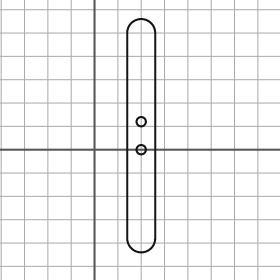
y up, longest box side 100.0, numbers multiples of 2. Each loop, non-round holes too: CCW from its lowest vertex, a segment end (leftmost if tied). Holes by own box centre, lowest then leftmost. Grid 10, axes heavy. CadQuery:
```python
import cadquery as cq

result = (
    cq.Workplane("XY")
    .moveTo(14.0, -38.0)
    .threePointArc((20.0, -44.0), (26.0, -38.0))
    .lineTo(26.0, 50.0)
    .threePointArc((20.0, 56.0), (14.0, 50.0))
    .close()
    .moveTo(20.0, 0.0)
    .circle(2.0)
    .moveTo(20.0, 12.0)
    .circle(2.0)
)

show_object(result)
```